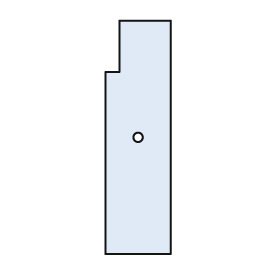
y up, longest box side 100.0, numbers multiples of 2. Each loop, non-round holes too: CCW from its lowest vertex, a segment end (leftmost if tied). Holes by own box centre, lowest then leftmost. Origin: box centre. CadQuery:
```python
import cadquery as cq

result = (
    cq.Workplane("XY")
    .moveTo(-14.0, -50.0)
    .lineTo(14.0, -50.0)
    .lineTo(14.0, 50.0)
    .lineTo(-8.0, 50.0)
    .lineTo(-8.0, 28.0)
    .lineTo(-14.0, 28.0)
    .close()
    .moveTo(0.0, 0.0)
    .circle(2.0)
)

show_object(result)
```